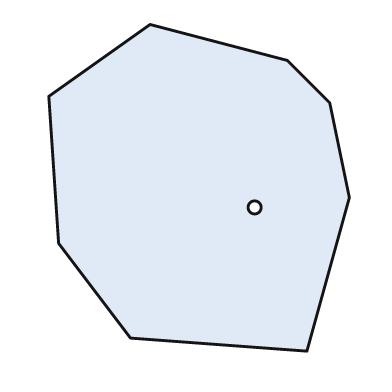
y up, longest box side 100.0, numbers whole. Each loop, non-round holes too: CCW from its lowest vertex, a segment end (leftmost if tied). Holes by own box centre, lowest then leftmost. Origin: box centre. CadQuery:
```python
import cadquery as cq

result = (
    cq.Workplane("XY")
    .moveTo(33.0, -50.0)
    .lineTo(46.0, -3.0)
    .lineTo(40.0, 26.0)
    .lineTo(27.0, 39.0)
    .lineTo(-15.0, 50.0)
    .lineTo(-46.0, 28.0)
    .lineTo(-43.0, -17.0)
    .lineTo(-21.0, -46.0)
    .close()
    .moveTo(17.0, -6.0)
    .circle(2.0)
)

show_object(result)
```